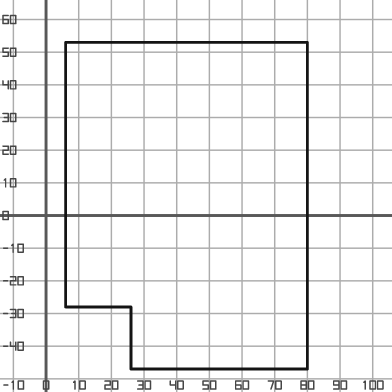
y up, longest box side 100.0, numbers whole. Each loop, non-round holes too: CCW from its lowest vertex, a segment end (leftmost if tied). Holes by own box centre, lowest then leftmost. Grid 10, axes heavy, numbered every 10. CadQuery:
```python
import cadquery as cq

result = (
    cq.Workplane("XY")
    .moveTo(26.0, -47.0)
    .lineTo(80.0, -47.0)
    .lineTo(80.0, 53.0)
    .lineTo(6.0, 53.0)
    .lineTo(6.0, -28.0)
    .lineTo(26.0, -28.0)
    .close()
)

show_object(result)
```